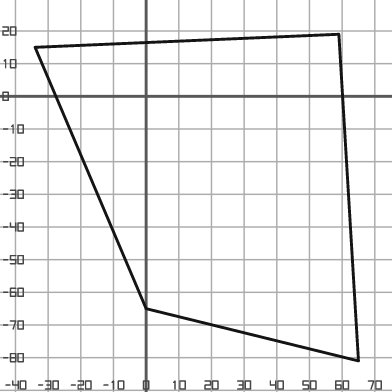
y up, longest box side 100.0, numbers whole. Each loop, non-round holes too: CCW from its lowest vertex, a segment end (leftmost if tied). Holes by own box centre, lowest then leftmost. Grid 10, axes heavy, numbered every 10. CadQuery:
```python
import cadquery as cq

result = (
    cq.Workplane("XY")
    .moveTo(65.0, -81.0)
    .lineTo(59.0, 19.0)
    .lineTo(-34.0, 15.0)
    .lineTo(0.0, -65.0)
    .close()
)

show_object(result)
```